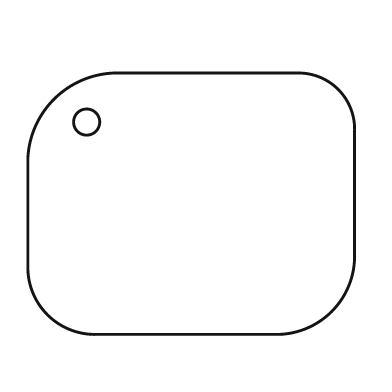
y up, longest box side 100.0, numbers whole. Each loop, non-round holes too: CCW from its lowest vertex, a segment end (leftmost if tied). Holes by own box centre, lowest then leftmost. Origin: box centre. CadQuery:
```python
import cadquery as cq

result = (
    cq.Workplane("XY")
    .moveTo(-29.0, -40.0)
    .lineTo(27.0, -40.0)
    .threePointArc((43.0, -33.0), (50.0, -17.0))
    .lineTo(50.0, 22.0)
    .threePointArc((45.0, 35.0), (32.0, 40.0))
    .lineTo(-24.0, 40.0)
    .threePointArc((-42.0, 32.0), (-50.0, 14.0))
    .lineTo(-50.0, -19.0)
    .threePointArc((-44.0, -34.0), (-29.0, -40.0))
    .close()
    .moveTo(-32.0, 25.0)
    .circle(4.0)
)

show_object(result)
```